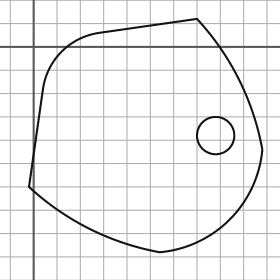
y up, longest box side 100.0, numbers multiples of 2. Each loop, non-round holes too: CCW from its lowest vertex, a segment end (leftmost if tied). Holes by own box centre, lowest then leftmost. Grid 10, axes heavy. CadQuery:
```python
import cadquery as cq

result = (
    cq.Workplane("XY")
    .moveTo(54.0, -88.0)
    .threePointArc((84.0, -74.0), (98.0, -44.0))
    .threePointArc((88.0, -14.0), (70.0, 12.0))
    .lineTo(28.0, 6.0)
    .threePointArc((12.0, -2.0), (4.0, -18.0))
    .lineTo(-2.0, -60.0)
    .threePointArc((24.0, -78.0), (54.0, -88.0))
    .close()
    .moveTo(78.0, -38.0)
    .circle(8.0)
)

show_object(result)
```